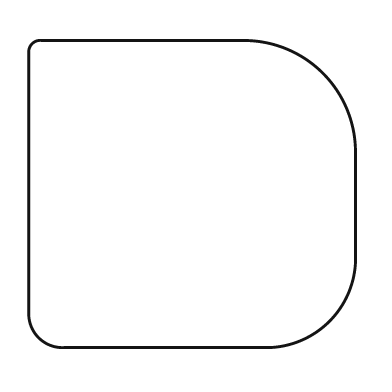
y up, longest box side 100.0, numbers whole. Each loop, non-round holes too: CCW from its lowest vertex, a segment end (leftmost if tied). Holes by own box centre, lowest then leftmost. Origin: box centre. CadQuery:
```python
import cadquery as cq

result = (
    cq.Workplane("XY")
    .moveTo(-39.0, -47.0)
    .lineTo(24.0, -47.0)
    .threePointArc((42.0, -39.0), (50.0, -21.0))
    .lineTo(50.0, 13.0)
    .threePointArc((40.0, 37.0), (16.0, 47.0))
    .lineTo(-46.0, 47.0)
    .threePointArc((-49.0, 46.0), (-50.0, 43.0))
    .lineTo(-50.0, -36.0)
    .threePointArc((-47.0, -44.0), (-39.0, -47.0))
    .close()
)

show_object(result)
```